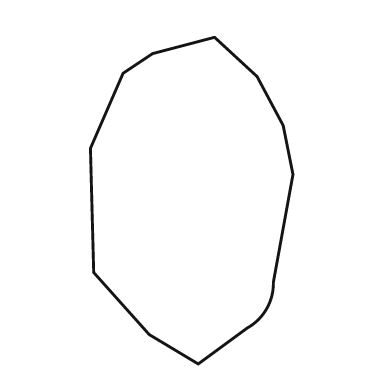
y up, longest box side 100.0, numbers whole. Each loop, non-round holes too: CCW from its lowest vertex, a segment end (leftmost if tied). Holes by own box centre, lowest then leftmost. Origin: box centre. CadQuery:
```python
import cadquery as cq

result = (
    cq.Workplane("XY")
    .moveTo(2.0, -50.0)
    .lineTo(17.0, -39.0)
    .threePointArc((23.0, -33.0), (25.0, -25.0))
    .lineTo(31.0, 8.0)
    .lineTo(28.0, 23.0)
    .lineTo(20.0, 38.0)
    .lineTo(7.0, 50.0)
    .lineTo(-12.0, 45.0)
    .lineTo(-21.0, 39.0)
    .lineTo(-31.0, 16.0)
    .lineTo(-30.0, -22.0)
    .lineTo(-13.0, -41.0)
    .close()
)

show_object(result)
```